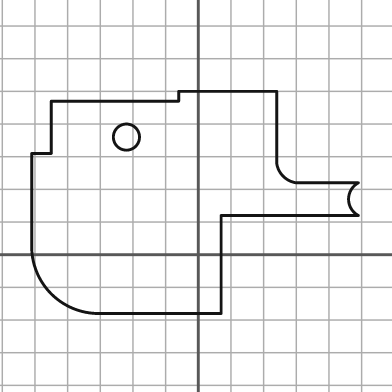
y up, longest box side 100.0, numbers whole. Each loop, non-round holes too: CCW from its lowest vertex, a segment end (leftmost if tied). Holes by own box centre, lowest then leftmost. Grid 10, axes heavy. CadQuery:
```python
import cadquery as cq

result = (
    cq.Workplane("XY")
    .moveTo(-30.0, -18.0)
    .lineTo(7.0, -18.0)
    .lineTo(7.0, 12.0)
    .lineTo(49.0, 12.0)
    .threePointArc((46.0, 17.0), (49.0, 22.0))
    .lineTo(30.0, 22.0)
    .threePointArc((26.0, 24.0), (24.0, 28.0))
    .lineTo(24.0, 50.0)
    .lineTo(-6.0, 50.0)
    .lineTo(-6.0, 47.0)
    .lineTo(-45.0, 47.0)
    .lineTo(-45.0, 31.0)
    .lineTo(-51.0, 31.0)
    .lineTo(-51.0, 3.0)
    .threePointArc((-45.0, -12.0), (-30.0, -18.0))
    .close()
    .moveTo(-22.0, 36.0)
    .circle(4.0)
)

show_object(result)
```